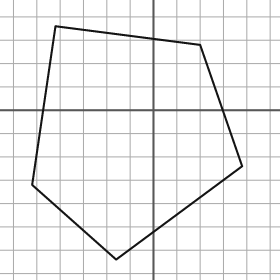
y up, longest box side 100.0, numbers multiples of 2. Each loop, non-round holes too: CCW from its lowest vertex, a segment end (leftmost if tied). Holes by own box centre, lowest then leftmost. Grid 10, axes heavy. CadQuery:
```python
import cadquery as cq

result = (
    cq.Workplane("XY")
    .moveTo(-16.0, -64.0)
    .lineTo(38.0, -24.0)
    .lineTo(20.0, 28.0)
    .lineTo(-42.0, 36.0)
    .lineTo(-52.0, -32.0)
    .close()
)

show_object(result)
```